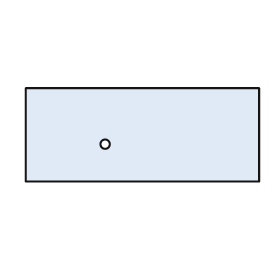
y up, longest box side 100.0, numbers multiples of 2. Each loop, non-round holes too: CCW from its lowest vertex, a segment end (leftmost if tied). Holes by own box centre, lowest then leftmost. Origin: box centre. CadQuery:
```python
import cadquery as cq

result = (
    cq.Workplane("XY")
    .moveTo(-50.0, -20.0)
    .lineTo(50.0, -20.0)
    .lineTo(50.0, 20.0)
    .lineTo(-50.0, 20.0)
    .close()
    .moveTo(-16.0, -4.0)
    .circle(2.0)
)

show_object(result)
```